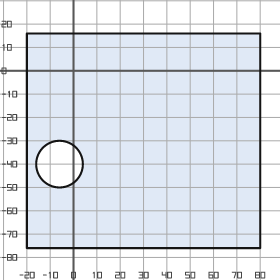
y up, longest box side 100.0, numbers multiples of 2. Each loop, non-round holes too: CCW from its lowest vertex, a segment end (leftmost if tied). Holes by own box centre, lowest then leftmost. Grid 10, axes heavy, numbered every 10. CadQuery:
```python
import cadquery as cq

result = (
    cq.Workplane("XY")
    .moveTo(-20.0, -76.0)
    .lineTo(80.0, -76.0)
    .lineTo(80.0, 16.0)
    .lineTo(-20.0, 16.0)
    .close()
    .moveTo(-6.0, -40.0)
    .circle(10.0)
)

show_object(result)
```